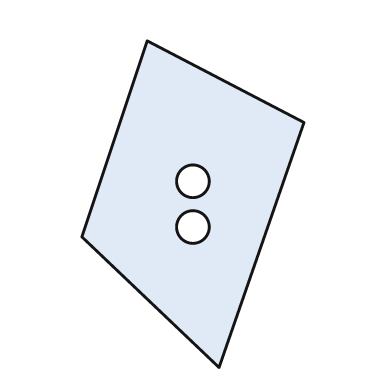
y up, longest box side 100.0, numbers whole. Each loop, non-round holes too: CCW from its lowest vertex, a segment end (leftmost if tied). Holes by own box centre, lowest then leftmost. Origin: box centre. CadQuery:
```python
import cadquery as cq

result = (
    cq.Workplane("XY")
    .moveTo(8.0, -50.0)
    .lineTo(34.0, 25.0)
    .lineTo(-14.0, 50.0)
    .lineTo(-34.0, -10.0)
    .close()
    .moveTo(0.0, -7.0)
    .circle(5.0)
    .moveTo(0.0, 7.0)
    .circle(5.0)
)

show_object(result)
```